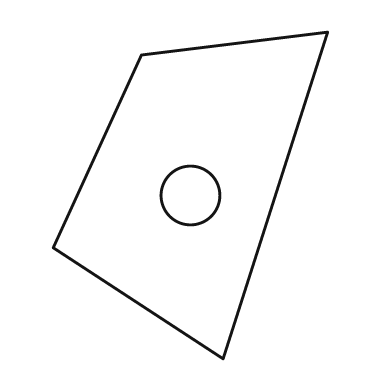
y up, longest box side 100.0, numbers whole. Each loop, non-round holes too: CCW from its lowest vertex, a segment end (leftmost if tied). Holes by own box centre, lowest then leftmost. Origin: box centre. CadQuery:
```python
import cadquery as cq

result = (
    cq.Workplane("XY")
    .moveTo(10.0, -50.0)
    .lineTo(42.0, 50.0)
    .lineTo(-15.0, 43.0)
    .lineTo(-42.0, -16.0)
    .close()
    .moveTo(0.0, 0.0)
    .circle(9.0)
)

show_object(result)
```